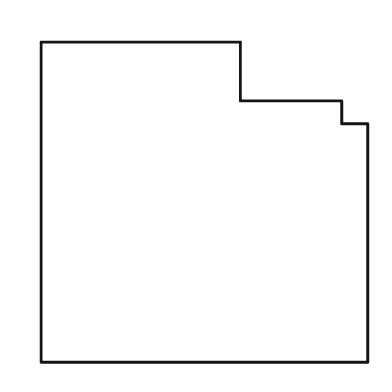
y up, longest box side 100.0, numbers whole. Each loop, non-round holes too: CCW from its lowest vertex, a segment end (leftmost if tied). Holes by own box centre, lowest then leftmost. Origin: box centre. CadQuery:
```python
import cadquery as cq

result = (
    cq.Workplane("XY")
    .moveTo(-50.0, -49.0)
    .lineTo(50.0, -49.0)
    .lineTo(50.0, 24.0)
    .lineTo(42.0, 24.0)
    .lineTo(42.0, 31.0)
    .lineTo(11.0, 31.0)
    .lineTo(11.0, 49.0)
    .lineTo(-50.0, 49.0)
    .close()
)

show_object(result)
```